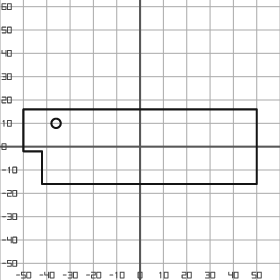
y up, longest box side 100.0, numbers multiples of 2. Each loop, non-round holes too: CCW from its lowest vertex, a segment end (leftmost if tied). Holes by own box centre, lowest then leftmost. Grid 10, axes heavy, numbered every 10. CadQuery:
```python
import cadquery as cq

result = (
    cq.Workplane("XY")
    .moveTo(-42.0, -16.0)
    .lineTo(50.0, -16.0)
    .lineTo(50.0, 16.0)
    .lineTo(-50.0, 16.0)
    .lineTo(-50.0, -2.0)
    .lineTo(-42.0, -2.0)
    .close()
    .moveTo(-36.0, 10.0)
    .circle(2.0)
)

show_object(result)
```